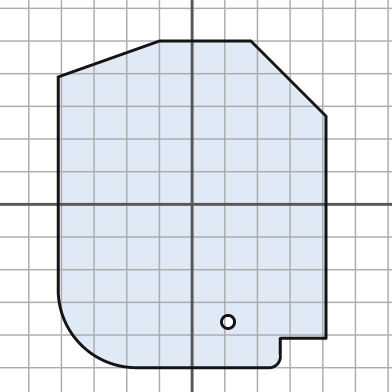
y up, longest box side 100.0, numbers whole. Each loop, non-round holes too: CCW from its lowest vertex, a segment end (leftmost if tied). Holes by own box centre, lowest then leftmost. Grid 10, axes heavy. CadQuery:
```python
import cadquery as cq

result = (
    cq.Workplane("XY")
    .moveTo(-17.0, -50.0)
    .lineTo(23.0, -50.0)
    .threePointArc((26.0, -49.0), (27.0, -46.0))
    .lineTo(27.0, -41.0)
    .lineTo(41.0, -41.0)
    .lineTo(41.0, 27.0)
    .lineTo(18.0, 50.0)
    .lineTo(-10.0, 50.0)
    .lineTo(-41.0, 39.0)
    .lineTo(-41.0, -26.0)
    .threePointArc((-34.0, -43.0), (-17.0, -50.0))
    .close()
    .moveTo(11.0, -36.0)
    .circle(2.0)
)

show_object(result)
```